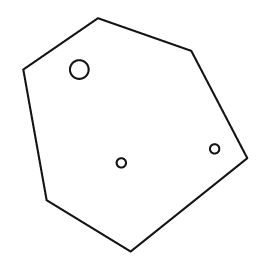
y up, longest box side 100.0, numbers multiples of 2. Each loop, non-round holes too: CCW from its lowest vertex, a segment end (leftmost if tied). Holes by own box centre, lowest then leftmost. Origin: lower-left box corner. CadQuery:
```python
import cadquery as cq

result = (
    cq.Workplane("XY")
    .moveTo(46.0, 0.0)
    .lineTo(96.0, 40.0)
    .lineTo(72.0, 86.0)
    .lineTo(32.0, 100.0)
    .lineTo(0.0, 78.0)
    .lineTo(10.0, 22.0)
    .close()
    .moveTo(42.0, 38.0)
    .circle(2.0)
    .moveTo(82.0, 44.0)
    .circle(2.0)
    .moveTo(24.0, 78.0)
    .circle(4.0)
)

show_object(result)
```